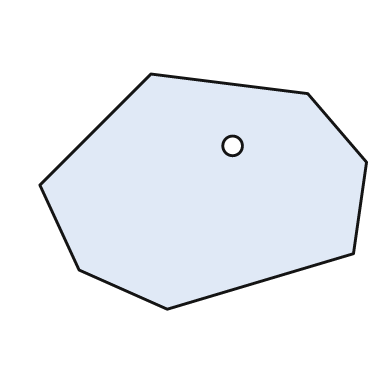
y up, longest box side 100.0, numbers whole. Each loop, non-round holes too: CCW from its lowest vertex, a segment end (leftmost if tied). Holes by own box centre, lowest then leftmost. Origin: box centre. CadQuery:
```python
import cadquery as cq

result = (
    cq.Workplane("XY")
    .moveTo(-11.0, -36.0)
    .lineTo(46.0, -19.0)
    .lineTo(50.0, 9.0)
    .lineTo(32.0, 30.0)
    .lineTo(-16.0, 36.0)
    .lineTo(-50.0, 2.0)
    .lineTo(-38.0, -24.0)
    .close()
    .moveTo(9.0, 14.0)
    .circle(3.0)
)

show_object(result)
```